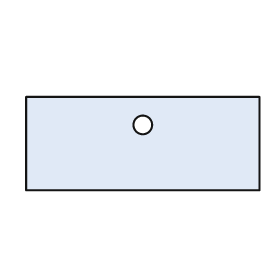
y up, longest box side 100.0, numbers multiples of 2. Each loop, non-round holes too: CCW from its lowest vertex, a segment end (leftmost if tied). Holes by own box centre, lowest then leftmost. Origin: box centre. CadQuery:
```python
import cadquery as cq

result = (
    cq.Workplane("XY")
    .moveTo(-50.0, -20.0)
    .lineTo(50.0, -20.0)
    .lineTo(50.0, 20.0)
    .lineTo(-50.0, 20.0)
    .close()
    .moveTo(0.0, 8.0)
    .circle(4.0)
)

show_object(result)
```